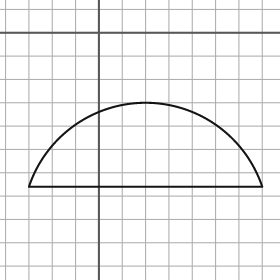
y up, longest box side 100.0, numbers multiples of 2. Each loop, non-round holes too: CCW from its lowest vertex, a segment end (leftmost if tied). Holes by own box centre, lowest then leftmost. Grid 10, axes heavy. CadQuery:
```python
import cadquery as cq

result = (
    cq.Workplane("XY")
    .moveTo(-30.0, -66.0)
    .lineTo(70.0, -66.0)
    .threePointArc((20.0, -30.0), (-30.0, -66.0))
    .close()
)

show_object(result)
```